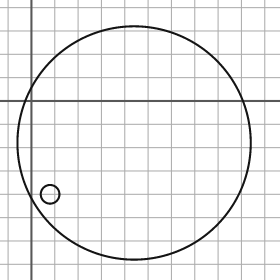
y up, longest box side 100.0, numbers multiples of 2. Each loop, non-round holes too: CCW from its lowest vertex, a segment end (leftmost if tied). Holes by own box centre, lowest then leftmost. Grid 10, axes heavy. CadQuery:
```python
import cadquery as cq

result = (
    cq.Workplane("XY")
    .moveTo(44.0, -18.0)
    .circle(50.0)
    .moveTo(8.0, -40.0)
    .circle(4.0)
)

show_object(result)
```